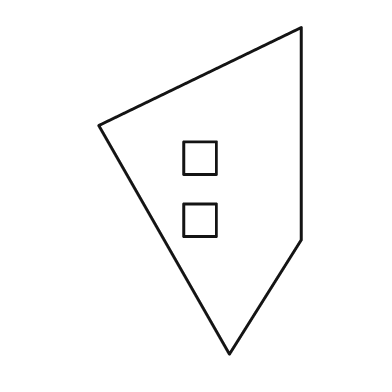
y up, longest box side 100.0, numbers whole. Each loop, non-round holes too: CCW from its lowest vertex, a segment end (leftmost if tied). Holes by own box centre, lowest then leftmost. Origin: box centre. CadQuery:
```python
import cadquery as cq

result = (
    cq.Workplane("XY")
    .moveTo(9.0, -50.0)
    .lineTo(31.0, -15.0)
    .lineTo(31.0, 50.0)
    .lineTo(-31.0, 20.0)
    .close()
    .moveTo(-5.0, -14.0)
    .lineTo(5.0, -14.0)
    .lineTo(5.0, -4.0)
    .lineTo(-5.0, -4.0)
    .close()
    .moveTo(-5.0, 5.0)
    .lineTo(5.0, 5.0)
    .lineTo(5.0, 15.0)
    .lineTo(-5.0, 15.0)
    .close()
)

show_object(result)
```